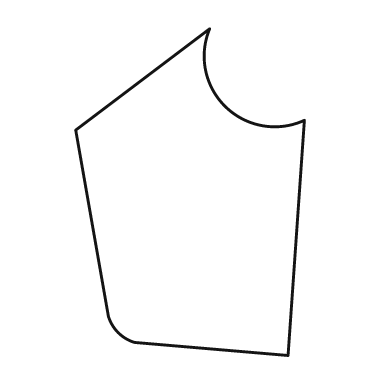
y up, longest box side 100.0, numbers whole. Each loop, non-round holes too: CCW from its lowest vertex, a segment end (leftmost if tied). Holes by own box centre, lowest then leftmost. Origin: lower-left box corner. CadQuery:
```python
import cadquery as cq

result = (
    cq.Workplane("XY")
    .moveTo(65.0, 0.0)
    .lineTo(70.0, 72.0)
    .threePointArc((46.0, 76.0), (41.0, 100.0))
    .lineTo(0.0, 69.0)
    .lineTo(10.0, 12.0)
    .threePointArc((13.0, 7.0), (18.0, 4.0))
    .close()
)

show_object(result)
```